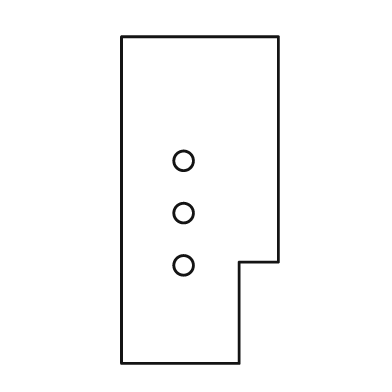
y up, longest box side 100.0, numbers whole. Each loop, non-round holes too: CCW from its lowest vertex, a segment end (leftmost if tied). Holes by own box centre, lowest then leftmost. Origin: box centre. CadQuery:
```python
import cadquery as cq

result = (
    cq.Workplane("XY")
    .moveTo(-24.0, -50.0)
    .lineTo(12.0, -50.0)
    .lineTo(12.0, -19.0)
    .lineTo(24.0, -19.0)
    .lineTo(24.0, 50.0)
    .lineTo(-24.0, 50.0)
    .close()
    .moveTo(-5.0, -20.0)
    .circle(3.0)
    .moveTo(-5.0, -4.0)
    .circle(3.0)
    .moveTo(-5.0, 12.0)
    .circle(3.0)
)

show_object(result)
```